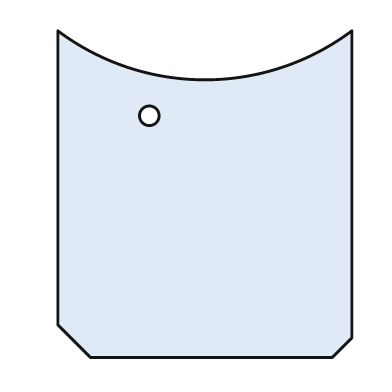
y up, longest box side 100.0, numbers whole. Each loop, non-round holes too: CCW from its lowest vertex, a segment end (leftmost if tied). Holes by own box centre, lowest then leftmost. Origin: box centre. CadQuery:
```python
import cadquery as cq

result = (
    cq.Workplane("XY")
    .moveTo(-35.0, -50.0)
    .lineTo(39.0, -50.0)
    .lineTo(45.0, -44.0)
    .lineTo(45.0, 50.0)
    .threePointArc((0.0, 35.0), (-45.0, 50.0))
    .lineTo(-45.0, -40.0)
    .close()
    .moveTo(-17.0, 24.0)
    .circle(3.0)
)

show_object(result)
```